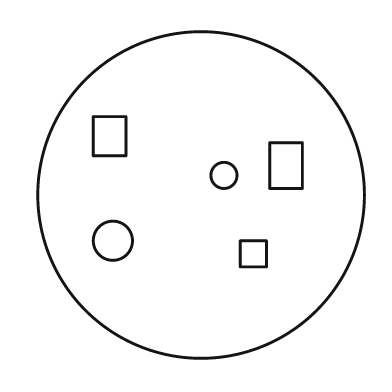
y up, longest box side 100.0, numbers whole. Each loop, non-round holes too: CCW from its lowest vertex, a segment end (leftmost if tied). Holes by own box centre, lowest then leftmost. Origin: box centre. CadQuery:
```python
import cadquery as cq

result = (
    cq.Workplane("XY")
    .moveTo(0.0, 0.0)
    .circle(50.0)
    .moveTo(12.0, -22.0)
    .lineTo(20.0, -22.0)
    .lineTo(20.0, -14.0)
    .lineTo(12.0, -14.0)
    .close()
    .moveTo(-27.0, -14.0)
    .circle(6.0)
    .moveTo(7.0, 6.0)
    .circle(4.0)
    .moveTo(21.0, 2.0)
    .lineTo(31.0, 2.0)
    .lineTo(31.0, 16.0)
    .lineTo(21.0, 16.0)
    .close()
    .moveTo(-33.0, 12.0)
    .lineTo(-23.0, 12.0)
    .lineTo(-23.0, 24.0)
    .lineTo(-33.0, 24.0)
    .close()
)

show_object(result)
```